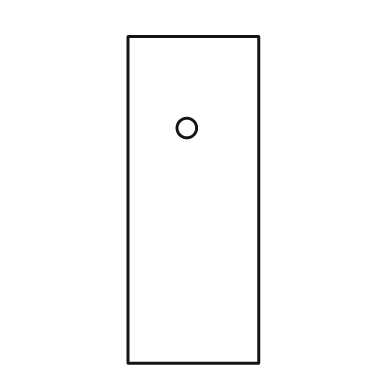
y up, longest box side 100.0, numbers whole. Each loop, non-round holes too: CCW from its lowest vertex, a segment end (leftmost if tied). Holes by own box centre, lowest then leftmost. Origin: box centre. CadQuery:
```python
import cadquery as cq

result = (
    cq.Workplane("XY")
    .moveTo(-20.0, -50.0)
    .lineTo(20.0, -50.0)
    .lineTo(20.0, 50.0)
    .lineTo(-20.0, 50.0)
    .close()
    .moveTo(-2.0, 22.0)
    .circle(3.0)
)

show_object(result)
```